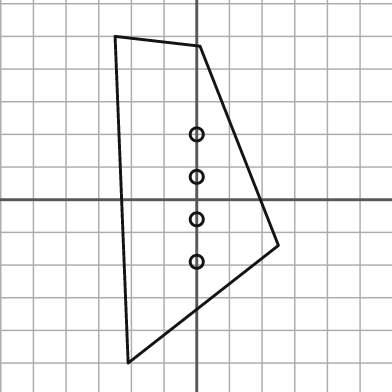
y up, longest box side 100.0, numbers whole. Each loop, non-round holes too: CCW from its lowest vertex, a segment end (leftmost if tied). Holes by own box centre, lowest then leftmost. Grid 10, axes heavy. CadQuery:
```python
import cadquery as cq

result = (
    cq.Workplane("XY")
    .moveTo(-21.0, -50.0)
    .lineTo(25.0, -14.0)
    .lineTo(1.0, 47.0)
    .lineTo(-25.0, 50.0)
    .close()
    .moveTo(0.0, -19.0)
    .circle(2.0)
    .moveTo(0.0, -6.0)
    .circle(2.0)
    .moveTo(0.0, 7.0)
    .circle(2.0)
    .moveTo(0.0, 20.0)
    .circle(2.0)
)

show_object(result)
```